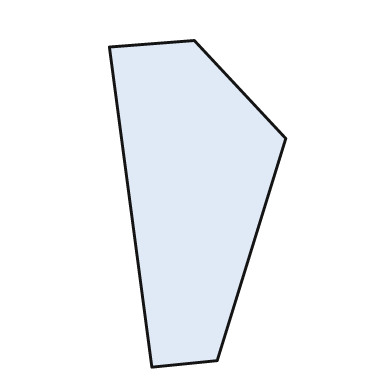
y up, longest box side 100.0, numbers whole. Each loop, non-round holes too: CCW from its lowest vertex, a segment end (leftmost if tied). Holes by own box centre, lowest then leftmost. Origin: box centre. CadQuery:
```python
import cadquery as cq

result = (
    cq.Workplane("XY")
    .moveTo(-14.0, -50.0)
    .lineTo(6.0, -48.0)
    .lineTo(27.0, 20.0)
    .lineTo(-1.0, 50.0)
    .lineTo(-27.0, 48.0)
    .close()
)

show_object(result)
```